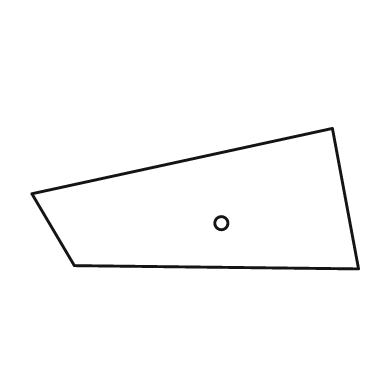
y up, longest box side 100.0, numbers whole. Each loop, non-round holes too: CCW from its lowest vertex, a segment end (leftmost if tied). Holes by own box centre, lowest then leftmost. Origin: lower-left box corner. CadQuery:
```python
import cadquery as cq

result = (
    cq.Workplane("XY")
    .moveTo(100.0, 0.0)
    .lineTo(92.0, 43.0)
    .lineTo(0.0, 23.0)
    .lineTo(13.0, 1.0)
    .close()
    .moveTo(58.0, 14.0)
    .circle(2.0)
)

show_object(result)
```